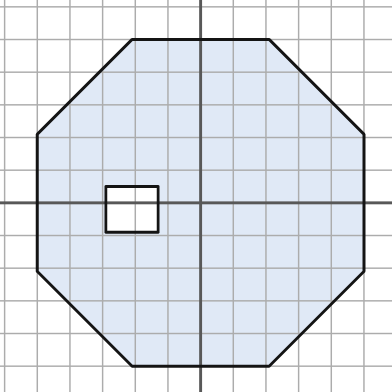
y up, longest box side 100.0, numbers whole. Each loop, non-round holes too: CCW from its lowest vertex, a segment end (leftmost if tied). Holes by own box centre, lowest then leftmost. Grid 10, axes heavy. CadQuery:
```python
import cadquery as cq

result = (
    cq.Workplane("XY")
    .moveTo(-21.0, -50.0)
    .lineTo(21.0, -50.0)
    .lineTo(50.0, -21.0)
    .lineTo(50.0, 21.0)
    .lineTo(21.0, 50.0)
    .lineTo(-21.0, 50.0)
    .lineTo(-50.0, 21.0)
    .lineTo(-50.0, -21.0)
    .close()
    .moveTo(-29.0, -9.0)
    .lineTo(-13.0, -9.0)
    .lineTo(-13.0, 5.0)
    .lineTo(-29.0, 5.0)
    .close()
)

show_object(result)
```